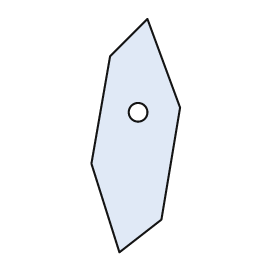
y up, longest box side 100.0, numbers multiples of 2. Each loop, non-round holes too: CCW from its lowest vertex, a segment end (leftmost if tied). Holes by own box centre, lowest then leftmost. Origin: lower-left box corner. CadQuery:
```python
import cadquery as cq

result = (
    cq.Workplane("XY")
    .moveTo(12.0, 0.0)
    .lineTo(30.0, 14.0)
    .lineTo(38.0, 62.0)
    .lineTo(24.0, 100.0)
    .lineTo(8.0, 84.0)
    .lineTo(0.0, 38.0)
    .close()
    .moveTo(20.0, 60.0)
    .circle(4.0)
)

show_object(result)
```